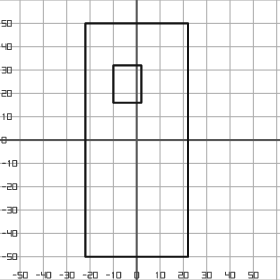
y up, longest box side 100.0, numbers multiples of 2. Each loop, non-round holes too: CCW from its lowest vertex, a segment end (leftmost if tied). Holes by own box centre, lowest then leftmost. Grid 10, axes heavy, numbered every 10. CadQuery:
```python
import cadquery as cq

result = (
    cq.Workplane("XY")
    .moveTo(-22.0, -50.0)
    .lineTo(22.0, -50.0)
    .lineTo(22.0, 50.0)
    .lineTo(-22.0, 50.0)
    .close()
    .moveTo(-10.0, 16.0)
    .lineTo(2.0, 16.0)
    .lineTo(2.0, 32.0)
    .lineTo(-10.0, 32.0)
    .close()
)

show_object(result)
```